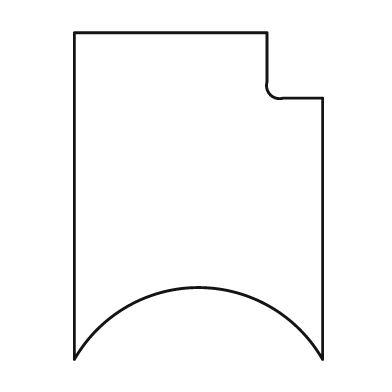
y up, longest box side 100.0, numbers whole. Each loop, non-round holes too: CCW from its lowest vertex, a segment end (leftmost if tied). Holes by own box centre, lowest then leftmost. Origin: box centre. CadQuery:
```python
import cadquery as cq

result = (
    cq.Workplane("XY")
    .moveTo(-38.0, -50.0)
    .threePointArc((0.0, -28.0), (38.0, -50.0))
    .lineTo(38.0, 30.0)
    .lineTo(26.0, 30.0)
    .threePointArc((22.0, 31.0), (21.0, 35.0))
    .lineTo(21.0, 50.0)
    .lineTo(-38.0, 50.0)
    .close()
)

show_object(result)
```